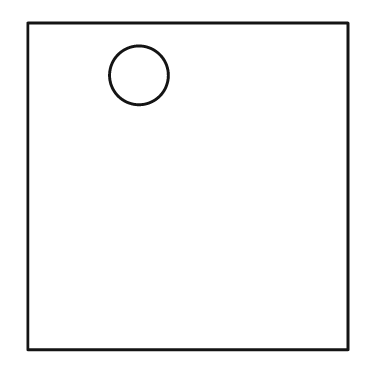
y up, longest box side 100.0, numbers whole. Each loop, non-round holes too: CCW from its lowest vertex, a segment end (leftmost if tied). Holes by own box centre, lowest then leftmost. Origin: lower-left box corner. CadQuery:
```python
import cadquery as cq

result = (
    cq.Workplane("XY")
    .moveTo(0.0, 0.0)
    .lineTo(98.0, 0.0)
    .lineTo(98.0, 100.0)
    .lineTo(0.0, 100.0)
    .close()
    .moveTo(34.0, 84.0)
    .circle(9.0)
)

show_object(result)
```